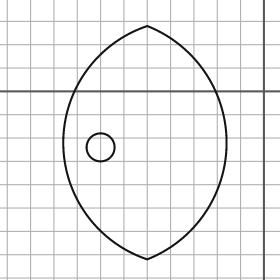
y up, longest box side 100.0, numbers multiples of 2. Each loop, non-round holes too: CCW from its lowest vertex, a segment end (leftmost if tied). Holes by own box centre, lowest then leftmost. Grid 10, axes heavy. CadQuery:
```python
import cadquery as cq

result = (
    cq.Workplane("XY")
    .moveTo(-50.0, -72.0)
    .threePointArc((-16.0, -22.0), (-50.0, 28.0))
    .threePointArc((-86.0, -22.0), (-50.0, -72.0))
    .close()
    .moveTo(-70.0, -24.0)
    .circle(6.0)
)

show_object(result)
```